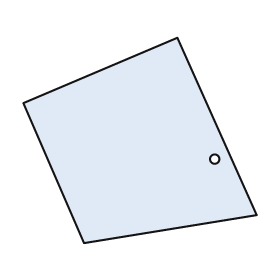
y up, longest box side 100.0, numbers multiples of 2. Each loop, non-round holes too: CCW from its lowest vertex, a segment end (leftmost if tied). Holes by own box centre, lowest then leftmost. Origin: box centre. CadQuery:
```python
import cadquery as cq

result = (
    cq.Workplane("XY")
    .moveTo(-24.0, -44.0)
    .lineTo(50.0, -32.0)
    .lineTo(16.0, 44.0)
    .lineTo(-50.0, 16.0)
    .close()
    .moveTo(32.0, -8.0)
    .circle(2.0)
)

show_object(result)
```